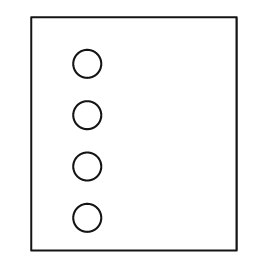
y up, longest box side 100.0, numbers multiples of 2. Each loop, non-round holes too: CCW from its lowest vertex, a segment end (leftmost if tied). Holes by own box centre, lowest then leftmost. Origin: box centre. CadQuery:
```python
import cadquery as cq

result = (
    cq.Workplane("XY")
    .moveTo(-44.0, -50.0)
    .lineTo(44.0, -50.0)
    .lineTo(44.0, 50.0)
    .lineTo(-44.0, 50.0)
    .close()
    .moveTo(-20.0, -36.0)
    .circle(6.0)
    .moveTo(-20.0, -14.0)
    .circle(6.0)
    .moveTo(-20.0, 8.0)
    .circle(6.0)
    .moveTo(-20.0, 30.0)
    .circle(6.0)
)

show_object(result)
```